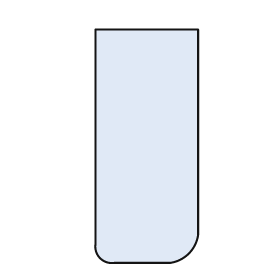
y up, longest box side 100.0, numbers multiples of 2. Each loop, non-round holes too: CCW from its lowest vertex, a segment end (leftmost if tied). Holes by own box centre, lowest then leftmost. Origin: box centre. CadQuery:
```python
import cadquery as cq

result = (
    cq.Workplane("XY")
    .moveTo(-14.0, -50.0)
    .lineTo(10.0, -50.0)
    .threePointArc((18.0, -46.0), (22.0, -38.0))
    .lineTo(22.0, 50.0)
    .lineTo(-22.0, 50.0)
    .lineTo(-22.0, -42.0)
    .threePointArc((-20.0, -48.0), (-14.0, -50.0))
    .close()
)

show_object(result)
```